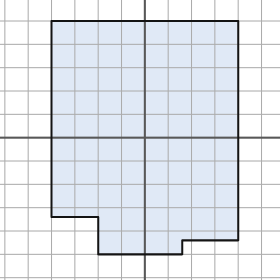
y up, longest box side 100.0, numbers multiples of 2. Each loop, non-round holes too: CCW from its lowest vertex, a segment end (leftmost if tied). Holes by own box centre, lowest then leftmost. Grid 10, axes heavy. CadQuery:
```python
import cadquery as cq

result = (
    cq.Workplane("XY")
    .moveTo(-20.0, -50.0)
    .lineTo(16.0, -50.0)
    .lineTo(16.0, -44.0)
    .lineTo(40.0, -44.0)
    .lineTo(40.0, 50.0)
    .lineTo(-40.0, 50.0)
    .lineTo(-40.0, -34.0)
    .lineTo(-20.0, -34.0)
    .close()
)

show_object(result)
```